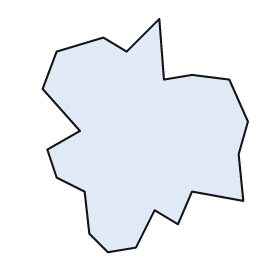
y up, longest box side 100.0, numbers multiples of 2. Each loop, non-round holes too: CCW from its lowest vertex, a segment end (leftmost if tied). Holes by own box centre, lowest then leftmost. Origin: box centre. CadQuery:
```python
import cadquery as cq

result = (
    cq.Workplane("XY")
    .moveTo(-16.0, -50.0)
    .lineTo(-4.0, -48.0)
    .lineTo(4.0, -32.0)
    .lineTo(14.0, -38.0)
    .lineTo(20.0, -24.0)
    .lineTo(42.0, -28.0)
    .lineTo(40.0, -8.0)
    .lineTo(44.0, 6.0)
    .lineTo(36.0, 24.0)
    .lineTo(20.0, 26.0)
    .lineTo(8.0, 24.0)
    .lineTo(6.0, 50.0)
    .lineTo(-8.0, 36.0)
    .lineTo(-18.0, 42.0)
    .lineTo(-38.0, 36.0)
    .lineTo(-44.0, 20.0)
    .lineTo(-28.0, 2.0)
    .lineTo(-42.0, -6.0)
    .lineTo(-38.0, -18.0)
    .lineTo(-26.0, -24.0)
    .lineTo(-24.0, -42.0)
    .close()
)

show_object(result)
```